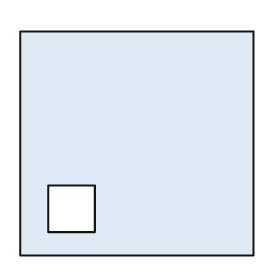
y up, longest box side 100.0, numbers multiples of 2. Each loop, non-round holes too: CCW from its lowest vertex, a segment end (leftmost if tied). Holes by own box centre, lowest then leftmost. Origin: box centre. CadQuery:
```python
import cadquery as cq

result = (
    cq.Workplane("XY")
    .moveTo(-50.0, -48.0)
    .lineTo(50.0, -48.0)
    .lineTo(50.0, 48.0)
    .lineTo(-50.0, 48.0)
    .close()
    .moveTo(-38.0, -38.0)
    .lineTo(-18.0, -38.0)
    .lineTo(-18.0, -18.0)
    .lineTo(-38.0, -18.0)
    .close()
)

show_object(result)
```